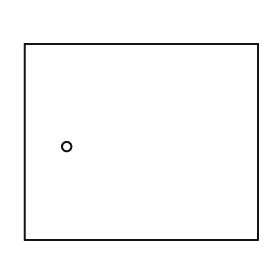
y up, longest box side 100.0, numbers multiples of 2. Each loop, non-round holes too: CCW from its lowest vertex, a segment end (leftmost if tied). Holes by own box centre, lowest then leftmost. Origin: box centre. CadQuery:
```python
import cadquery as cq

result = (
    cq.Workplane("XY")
    .moveTo(-50.0, -42.0)
    .lineTo(50.0, -42.0)
    .lineTo(50.0, 42.0)
    .lineTo(-50.0, 42.0)
    .close()
    .moveTo(-32.0, -2.0)
    .circle(2.0)
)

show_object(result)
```